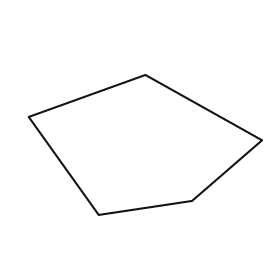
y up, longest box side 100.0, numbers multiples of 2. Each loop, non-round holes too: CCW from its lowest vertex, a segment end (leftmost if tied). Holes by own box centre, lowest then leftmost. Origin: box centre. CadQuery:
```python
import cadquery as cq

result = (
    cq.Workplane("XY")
    .moveTo(-20.0, -30.0)
    .lineTo(20.0, -24.0)
    .lineTo(50.0, 2.0)
    .lineTo(0.0, 30.0)
    .lineTo(-50.0, 12.0)
    .close()
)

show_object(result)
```